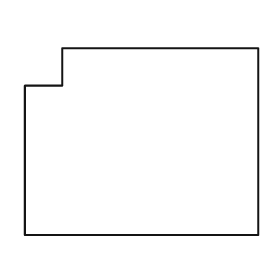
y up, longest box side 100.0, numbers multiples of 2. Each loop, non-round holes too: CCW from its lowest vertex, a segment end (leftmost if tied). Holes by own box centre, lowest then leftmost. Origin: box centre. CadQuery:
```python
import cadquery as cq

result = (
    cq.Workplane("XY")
    .moveTo(-50.0, -40.0)
    .lineTo(50.0, -40.0)
    .lineTo(50.0, 40.0)
    .lineTo(-34.0, 40.0)
    .lineTo(-34.0, 24.0)
    .lineTo(-50.0, 24.0)
    .close()
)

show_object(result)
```